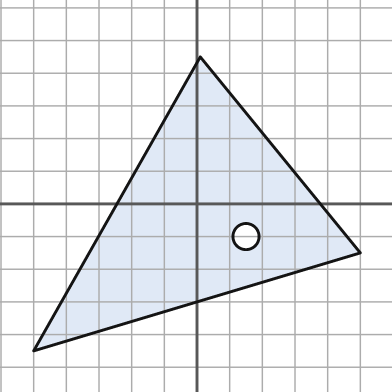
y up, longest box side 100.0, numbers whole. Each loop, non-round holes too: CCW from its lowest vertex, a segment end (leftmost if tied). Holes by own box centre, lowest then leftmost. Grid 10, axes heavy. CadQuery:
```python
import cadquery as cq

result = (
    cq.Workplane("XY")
    .moveTo(-50.0, -45.0)
    .lineTo(50.0, -15.0)
    .lineTo(1.0, 45.0)
    .close()
    .moveTo(15.0, -10.0)
    .circle(4.0)
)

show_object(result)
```